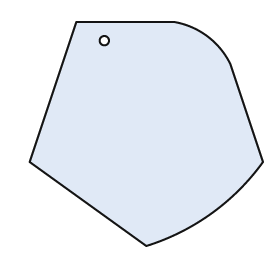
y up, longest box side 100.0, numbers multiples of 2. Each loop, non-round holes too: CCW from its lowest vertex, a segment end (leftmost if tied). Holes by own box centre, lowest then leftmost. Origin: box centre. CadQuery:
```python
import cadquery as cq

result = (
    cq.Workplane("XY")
    .moveTo(0.0, -48.0)
    .threePointArc((28.0, -34.0), (50.0, -12.0))
    .lineTo(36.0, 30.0)
    .threePointArc((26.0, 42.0), (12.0, 48.0))
    .lineTo(-30.0, 48.0)
    .lineTo(-50.0, -12.0)
    .close()
    .moveTo(-18.0, 40.0)
    .circle(2.0)
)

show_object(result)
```